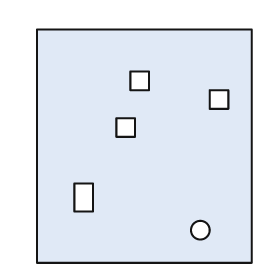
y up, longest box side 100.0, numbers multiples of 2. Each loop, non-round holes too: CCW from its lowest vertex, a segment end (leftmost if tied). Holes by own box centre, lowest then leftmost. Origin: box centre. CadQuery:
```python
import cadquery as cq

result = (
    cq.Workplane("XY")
    .moveTo(-46.0, -50.0)
    .lineTo(46.0, -50.0)
    .lineTo(46.0, 50.0)
    .lineTo(-46.0, 50.0)
    .close()
    .moveTo(24.0, -36.0)
    .circle(4.0)
    .moveTo(-30.0, -28.0)
    .lineTo(-22.0, -28.0)
    .lineTo(-22.0, -16.0)
    .lineTo(-30.0, -16.0)
    .close()
    .moveTo(-12.0, 4.0)
    .lineTo(-4.0, 4.0)
    .lineTo(-4.0, 12.0)
    .lineTo(-12.0, 12.0)
    .close()
    .moveTo(28.0, 16.0)
    .lineTo(36.0, 16.0)
    .lineTo(36.0, 24.0)
    .lineTo(28.0, 24.0)
    .close()
    .moveTo(-6.0, 24.0)
    .lineTo(2.0, 24.0)
    .lineTo(2.0, 32.0)
    .lineTo(-6.0, 32.0)
    .close()
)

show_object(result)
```